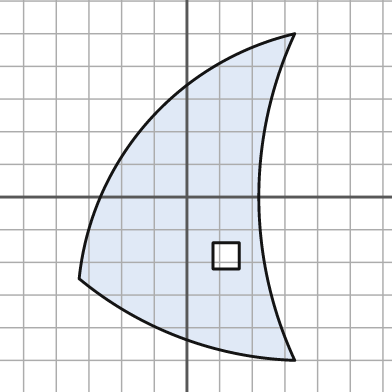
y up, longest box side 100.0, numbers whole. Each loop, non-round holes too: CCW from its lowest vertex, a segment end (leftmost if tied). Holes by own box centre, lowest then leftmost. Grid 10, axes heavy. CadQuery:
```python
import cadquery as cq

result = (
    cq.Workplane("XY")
    .moveTo(33.0, -50.0)
    .threePointArc((22.0, 0.0), (33.0, 50.0))
    .threePointArc((-12.0, 23.0), (-33.0, -25.0))
    .threePointArc((-2.0, -43.0), (33.0, -50.0))
    .close()
    .moveTo(8.0, -22.0)
    .lineTo(16.0, -22.0)
    .lineTo(16.0, -14.0)
    .lineTo(8.0, -14.0)
    .close()
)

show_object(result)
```